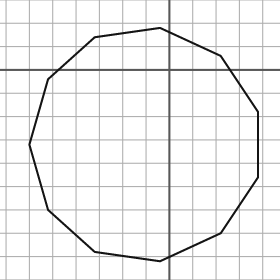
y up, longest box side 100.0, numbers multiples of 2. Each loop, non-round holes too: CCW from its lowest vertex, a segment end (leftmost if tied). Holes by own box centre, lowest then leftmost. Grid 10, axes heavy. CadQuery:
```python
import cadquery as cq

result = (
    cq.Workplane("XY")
    .moveTo(-4.0, -82.0)
    .lineTo(22.0, -70.0)
    .lineTo(38.0, -46.0)
    .lineTo(38.0, -18.0)
    .lineTo(22.0, 6.0)
    .lineTo(-4.0, 18.0)
    .lineTo(-32.0, 14.0)
    .lineTo(-52.0, -4.0)
    .lineTo(-60.0, -32.0)
    .lineTo(-52.0, -60.0)
    .lineTo(-32.0, -78.0)
    .close()
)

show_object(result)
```